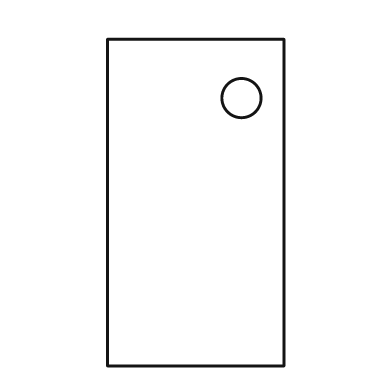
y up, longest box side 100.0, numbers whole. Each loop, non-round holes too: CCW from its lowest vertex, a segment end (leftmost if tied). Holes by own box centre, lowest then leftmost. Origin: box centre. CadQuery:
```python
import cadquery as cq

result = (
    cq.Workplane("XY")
    .moveTo(-27.0, -50.0)
    .lineTo(27.0, -50.0)
    .lineTo(27.0, 50.0)
    .lineTo(-27.0, 50.0)
    .close()
    .moveTo(14.0, 32.0)
    .circle(6.0)
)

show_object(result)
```